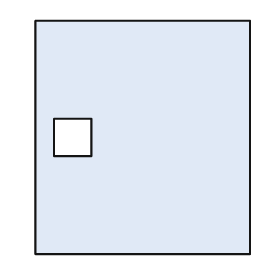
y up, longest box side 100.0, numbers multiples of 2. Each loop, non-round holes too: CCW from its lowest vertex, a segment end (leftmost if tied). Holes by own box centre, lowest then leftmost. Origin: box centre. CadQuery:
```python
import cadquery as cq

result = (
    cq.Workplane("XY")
    .moveTo(-46.0, -50.0)
    .lineTo(46.0, -50.0)
    .lineTo(46.0, 50.0)
    .lineTo(-46.0, 50.0)
    .close()
    .moveTo(-38.0, -8.0)
    .lineTo(-22.0, -8.0)
    .lineTo(-22.0, 8.0)
    .lineTo(-38.0, 8.0)
    .close()
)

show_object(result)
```